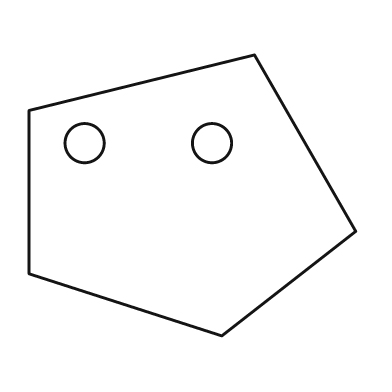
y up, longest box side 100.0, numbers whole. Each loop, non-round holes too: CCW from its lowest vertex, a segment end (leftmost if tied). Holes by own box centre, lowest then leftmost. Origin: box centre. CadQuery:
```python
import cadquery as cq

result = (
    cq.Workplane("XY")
    .moveTo(9.0, -43.0)
    .lineTo(50.0, -11.0)
    .lineTo(19.0, 43.0)
    .lineTo(-50.0, 26.0)
    .lineTo(-50.0, -24.0)
    .close()
    .moveTo(-33.0, 16.0)
    .circle(6.0)
    .moveTo(6.0, 16.0)
    .circle(6.0)
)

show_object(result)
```